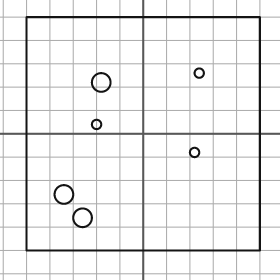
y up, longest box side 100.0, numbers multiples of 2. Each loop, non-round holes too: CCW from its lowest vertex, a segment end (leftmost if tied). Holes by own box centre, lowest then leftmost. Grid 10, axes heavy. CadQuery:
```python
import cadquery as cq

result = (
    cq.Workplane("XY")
    .moveTo(-50.0, -50.0)
    .lineTo(50.0, -50.0)
    .lineTo(50.0, 50.0)
    .lineTo(-50.0, 50.0)
    .close()
    .moveTo(-26.0, -36.0)
    .circle(4.0)
    .moveTo(-34.0, -26.0)
    .circle(4.0)
    .moveTo(22.0, -8.0)
    .circle(2.0)
    .moveTo(-20.0, 4.0)
    .circle(2.0)
    .moveTo(-18.0, 22.0)
    .circle(4.0)
    .moveTo(24.0, 26.0)
    .circle(2.0)
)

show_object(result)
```